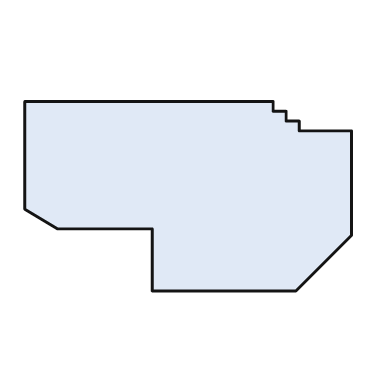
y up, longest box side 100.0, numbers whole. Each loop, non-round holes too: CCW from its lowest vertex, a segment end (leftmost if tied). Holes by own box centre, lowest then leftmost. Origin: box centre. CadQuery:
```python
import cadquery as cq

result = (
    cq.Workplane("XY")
    .moveTo(-11.0, -29.0)
    .lineTo(33.0, -29.0)
    .lineTo(50.0, -12.0)
    .lineTo(50.0, 20.0)
    .lineTo(34.0, 20.0)
    .lineTo(34.0, 23.0)
    .lineTo(30.0, 23.0)
    .lineTo(30.0, 26.0)
    .lineTo(26.0, 26.0)
    .lineTo(26.0, 29.0)
    .lineTo(-50.0, 29.0)
    .lineTo(-50.0, -4.0)
    .lineTo(-40.0, -10.0)
    .lineTo(-11.0, -10.0)
    .close()
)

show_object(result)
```